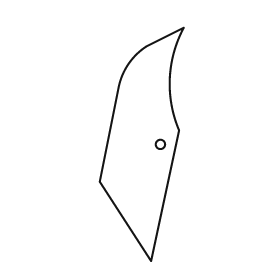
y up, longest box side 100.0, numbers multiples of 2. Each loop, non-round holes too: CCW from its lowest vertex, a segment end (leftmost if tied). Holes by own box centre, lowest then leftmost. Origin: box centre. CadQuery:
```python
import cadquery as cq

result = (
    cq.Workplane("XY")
    .moveTo(4.0, -50.0)
    .lineTo(16.0, 6.0)
    .threePointArc((12.0, 28.0), (18.0, 50.0))
    .lineTo(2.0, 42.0)
    .threePointArc((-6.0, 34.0), (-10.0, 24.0))
    .lineTo(-18.0, -16.0)
    .close()
    .moveTo(8.0, 0.0)
    .circle(2.0)
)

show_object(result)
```